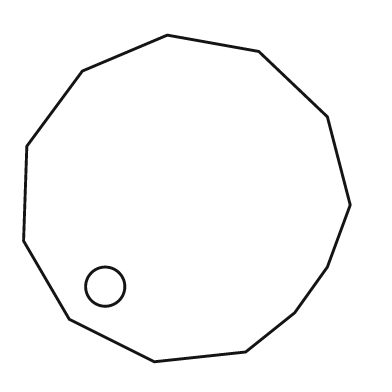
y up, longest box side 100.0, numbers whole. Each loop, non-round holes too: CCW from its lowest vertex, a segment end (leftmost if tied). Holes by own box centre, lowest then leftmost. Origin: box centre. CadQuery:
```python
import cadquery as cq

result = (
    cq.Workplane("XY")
    .moveTo(-10.0, -50.0)
    .lineTo(18.0, -47.0)
    .lineTo(33.0, -35.0)
    .lineTo(43.0, -21.0)
    .lineTo(50.0, -2.0)
    .lineTo(43.0, 25.0)
    .lineTo(22.0, 45.0)
    .lineTo(-6.0, 50.0)
    .lineTo(-32.0, 39.0)
    .lineTo(-49.0, 16.0)
    .lineTo(-50.0, -13.0)
    .lineTo(-36.0, -37.0)
    .close()
    .moveTo(-25.0, -27.0)
    .circle(6.0)
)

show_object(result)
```